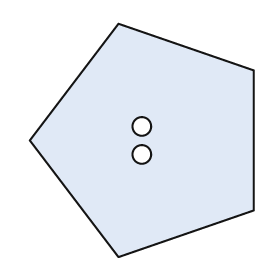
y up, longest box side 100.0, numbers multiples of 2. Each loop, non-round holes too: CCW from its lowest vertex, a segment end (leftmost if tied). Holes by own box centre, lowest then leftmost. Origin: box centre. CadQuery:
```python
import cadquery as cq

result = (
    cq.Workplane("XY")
    .moveTo(-10.0, -50.0)
    .lineTo(48.0, -30.0)
    .lineTo(48.0, 30.0)
    .lineTo(-10.0, 50.0)
    .lineTo(-48.0, 0.0)
    .close()
    .moveTo(0.0, -6.0)
    .circle(4.0)
    .moveTo(0.0, 6.0)
    .circle(4.0)
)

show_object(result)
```